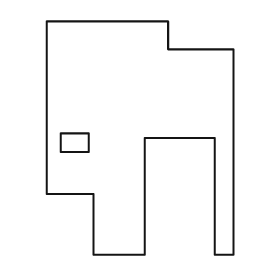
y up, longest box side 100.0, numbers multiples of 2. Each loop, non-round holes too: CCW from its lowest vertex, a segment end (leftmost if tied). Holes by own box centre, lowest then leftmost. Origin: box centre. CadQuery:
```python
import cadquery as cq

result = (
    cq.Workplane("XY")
    .moveTo(-20.0, -50.0)
    .lineTo(2.0, -50.0)
    .lineTo(2.0, 0.0)
    .lineTo(32.0, 0.0)
    .lineTo(32.0, -50.0)
    .lineTo(40.0, -50.0)
    .lineTo(40.0, 38.0)
    .lineTo(12.0, 38.0)
    .lineTo(12.0, 50.0)
    .lineTo(-40.0, 50.0)
    .lineTo(-40.0, -24.0)
    .lineTo(-20.0, -24.0)
    .close()
    .moveTo(-34.0, -6.0)
    .lineTo(-22.0, -6.0)
    .lineTo(-22.0, 2.0)
    .lineTo(-34.0, 2.0)
    .close()
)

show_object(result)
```